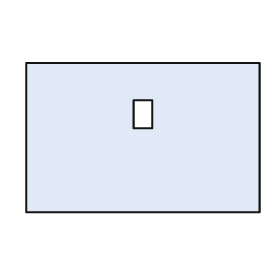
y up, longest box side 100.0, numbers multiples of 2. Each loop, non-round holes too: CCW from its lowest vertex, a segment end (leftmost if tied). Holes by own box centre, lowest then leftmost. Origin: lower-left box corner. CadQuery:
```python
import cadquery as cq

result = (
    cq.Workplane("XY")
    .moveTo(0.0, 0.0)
    .lineTo(100.0, 0.0)
    .lineTo(100.0, 64.0)
    .lineTo(0.0, 64.0)
    .close()
    .moveTo(46.0, 36.0)
    .lineTo(54.0, 36.0)
    .lineTo(54.0, 48.0)
    .lineTo(46.0, 48.0)
    .close()
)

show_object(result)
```